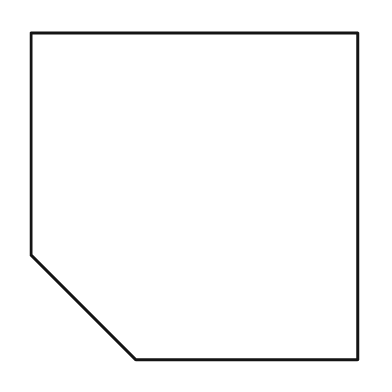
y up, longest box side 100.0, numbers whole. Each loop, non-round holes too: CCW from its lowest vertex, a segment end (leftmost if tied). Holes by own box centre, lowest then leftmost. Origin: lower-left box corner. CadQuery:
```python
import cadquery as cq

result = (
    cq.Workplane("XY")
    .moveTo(32.0, 0.0)
    .lineTo(100.0, 0.0)
    .lineTo(100.0, 100.0)
    .lineTo(0.0, 100.0)
    .lineTo(0.0, 32.0)
    .close()
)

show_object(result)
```